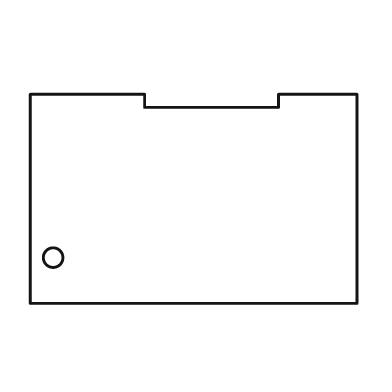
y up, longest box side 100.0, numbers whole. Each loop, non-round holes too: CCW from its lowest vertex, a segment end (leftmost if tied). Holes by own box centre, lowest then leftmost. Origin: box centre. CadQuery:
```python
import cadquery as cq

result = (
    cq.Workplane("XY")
    .moveTo(-50.0, -32.0)
    .lineTo(50.0, -32.0)
    .lineTo(50.0, 32.0)
    .lineTo(26.0, 32.0)
    .lineTo(26.0, 28.0)
    .lineTo(-15.0, 28.0)
    .lineTo(-15.0, 32.0)
    .lineTo(-50.0, 32.0)
    .close()
    .moveTo(-43.0, -18.0)
    .circle(3.0)
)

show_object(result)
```